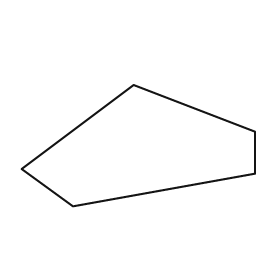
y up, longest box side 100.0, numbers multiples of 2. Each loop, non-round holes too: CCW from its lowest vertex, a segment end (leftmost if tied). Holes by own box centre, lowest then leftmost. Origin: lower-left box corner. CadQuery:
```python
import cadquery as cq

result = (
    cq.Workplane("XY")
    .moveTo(22.0, 0.0)
    .lineTo(100.0, 14.0)
    .lineTo(100.0, 32.0)
    .lineTo(48.0, 52.0)
    .lineTo(0.0, 16.0)
    .close()
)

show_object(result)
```